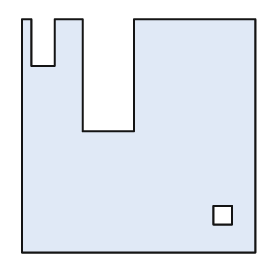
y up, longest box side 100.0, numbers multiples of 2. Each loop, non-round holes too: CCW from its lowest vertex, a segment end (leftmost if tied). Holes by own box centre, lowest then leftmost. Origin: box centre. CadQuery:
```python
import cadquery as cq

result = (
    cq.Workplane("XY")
    .moveTo(-50.0, -50.0)
    .lineTo(50.0, -50.0)
    .lineTo(50.0, 50.0)
    .lineTo(-2.0, 50.0)
    .lineTo(-2.0, 2.0)
    .lineTo(-24.0, 2.0)
    .lineTo(-24.0, 50.0)
    .lineTo(-36.0, 50.0)
    .lineTo(-36.0, 30.0)
    .lineTo(-46.0, 30.0)
    .lineTo(-46.0, 50.0)
    .lineTo(-50.0, 50.0)
    .close()
    .moveTo(32.0, -38.0)
    .lineTo(40.0, -38.0)
    .lineTo(40.0, -30.0)
    .lineTo(32.0, -30.0)
    .close()
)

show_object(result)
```